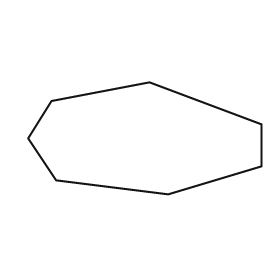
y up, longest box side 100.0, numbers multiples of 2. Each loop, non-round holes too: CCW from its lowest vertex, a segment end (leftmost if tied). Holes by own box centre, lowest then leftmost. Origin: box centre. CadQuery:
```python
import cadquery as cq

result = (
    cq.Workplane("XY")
    .moveTo(10.0, -24.0)
    .lineTo(50.0, -12.0)
    .lineTo(50.0, 6.0)
    .lineTo(2.0, 24.0)
    .lineTo(-40.0, 16.0)
    .lineTo(-50.0, 0.0)
    .lineTo(-38.0, -18.0)
    .close()
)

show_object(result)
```